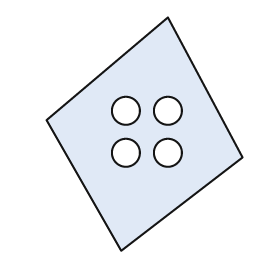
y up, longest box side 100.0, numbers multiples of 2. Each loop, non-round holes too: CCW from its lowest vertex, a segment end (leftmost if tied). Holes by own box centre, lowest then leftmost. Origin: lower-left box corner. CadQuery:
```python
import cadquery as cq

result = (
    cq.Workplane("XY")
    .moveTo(32.0, 0.0)
    .lineTo(84.0, 40.0)
    .lineTo(52.0, 100.0)
    .lineTo(0.0, 56.0)
    .close()
    .moveTo(34.0, 42.0)
    .circle(6.0)
    .moveTo(52.0, 42.0)
    .circle(6.0)
    .moveTo(34.0, 60.0)
    .circle(6.0)
    .moveTo(52.0, 60.0)
    .circle(6.0)
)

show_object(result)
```